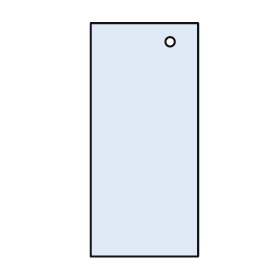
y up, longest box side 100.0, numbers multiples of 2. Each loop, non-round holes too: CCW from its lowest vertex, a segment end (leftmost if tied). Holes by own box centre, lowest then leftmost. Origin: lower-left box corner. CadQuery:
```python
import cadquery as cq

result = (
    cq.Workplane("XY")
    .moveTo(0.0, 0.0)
    .lineTo(46.0, 0.0)
    .lineTo(46.0, 100.0)
    .lineTo(0.0, 100.0)
    .close()
    .moveTo(34.0, 92.0)
    .circle(2.0)
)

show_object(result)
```